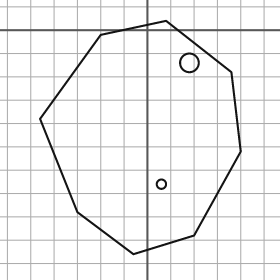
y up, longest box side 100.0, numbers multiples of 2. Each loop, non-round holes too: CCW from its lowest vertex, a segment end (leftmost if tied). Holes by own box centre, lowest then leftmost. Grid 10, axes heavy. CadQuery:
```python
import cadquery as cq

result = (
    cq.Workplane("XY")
    .moveTo(-6.0, -96.0)
    .lineTo(20.0, -88.0)
    .lineTo(40.0, -52.0)
    .lineTo(36.0, -18.0)
    .lineTo(8.0, 4.0)
    .lineTo(-20.0, -2.0)
    .lineTo(-46.0, -38.0)
    .lineTo(-30.0, -78.0)
    .close()
    .moveTo(6.0, -66.0)
    .circle(2.0)
    .moveTo(18.0, -14.0)
    .circle(4.0)
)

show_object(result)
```